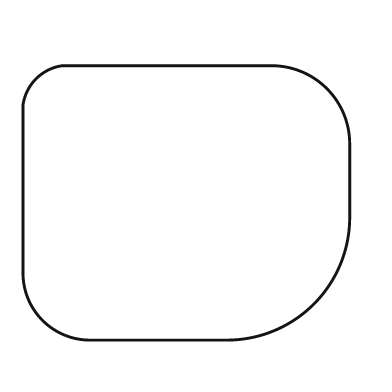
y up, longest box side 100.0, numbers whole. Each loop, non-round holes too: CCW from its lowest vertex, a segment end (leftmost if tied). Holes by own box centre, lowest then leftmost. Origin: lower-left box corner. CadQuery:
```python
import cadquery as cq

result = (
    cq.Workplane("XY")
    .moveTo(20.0, 0.0)
    .lineTo(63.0, 0.0)
    .threePointArc((89.0, 11.0), (100.0, 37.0))
    .lineTo(100.0, 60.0)
    .threePointArc((93.0, 77.0), (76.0, 84.0))
    .lineTo(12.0, 84.0)
    .threePointArc((4.0, 80.0), (0.0, 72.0))
    .lineTo(0.0, 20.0)
    .threePointArc((6.0, 6.0), (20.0, 0.0))
    .close()
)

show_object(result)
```